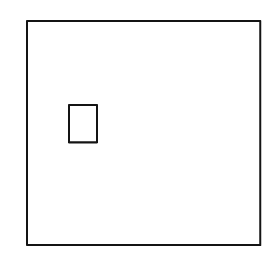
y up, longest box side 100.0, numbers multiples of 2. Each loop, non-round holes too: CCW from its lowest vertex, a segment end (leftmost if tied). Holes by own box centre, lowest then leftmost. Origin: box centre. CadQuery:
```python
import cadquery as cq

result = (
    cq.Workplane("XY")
    .moveTo(-50.0, -48.0)
    .lineTo(50.0, -48.0)
    .lineTo(50.0, 48.0)
    .lineTo(-50.0, 48.0)
    .close()
    .moveTo(-32.0, -4.0)
    .lineTo(-20.0, -4.0)
    .lineTo(-20.0, 12.0)
    .lineTo(-32.0, 12.0)
    .close()
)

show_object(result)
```